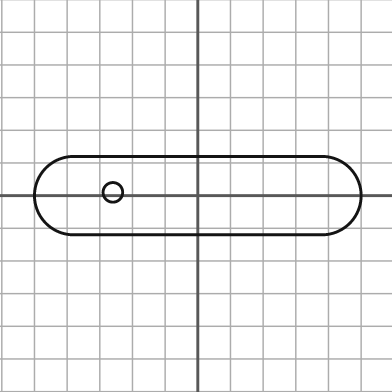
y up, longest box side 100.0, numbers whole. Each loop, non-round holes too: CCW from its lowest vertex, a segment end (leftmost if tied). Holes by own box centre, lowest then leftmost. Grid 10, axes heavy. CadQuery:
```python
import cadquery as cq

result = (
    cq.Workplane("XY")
    .moveTo(-38.0, -12.0)
    .lineTo(38.0, -12.0)
    .threePointArc((50.0, 0.0), (38.0, 12.0))
    .lineTo(-38.0, 12.0)
    .threePointArc((-50.0, 0.0), (-38.0, -12.0))
    .close()
    .moveTo(-26.0, 1.0)
    .circle(3.0)
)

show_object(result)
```